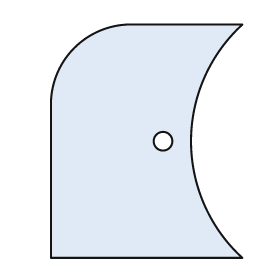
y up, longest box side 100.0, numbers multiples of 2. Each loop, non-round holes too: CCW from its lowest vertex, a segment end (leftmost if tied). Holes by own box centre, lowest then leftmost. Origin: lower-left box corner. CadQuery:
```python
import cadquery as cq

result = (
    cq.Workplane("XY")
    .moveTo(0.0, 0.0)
    .lineTo(82.0, 0.0)
    .threePointArc((60.0, 50.0), (82.0, 100.0))
    .lineTo(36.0, 100.0)
    .threePointArc((10.0, 90.0), (0.0, 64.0))
    .close()
    .moveTo(48.0, 50.0)
    .circle(4.0)
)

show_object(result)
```